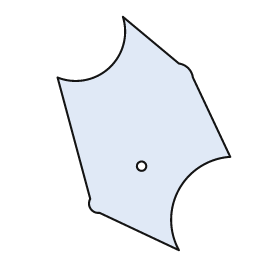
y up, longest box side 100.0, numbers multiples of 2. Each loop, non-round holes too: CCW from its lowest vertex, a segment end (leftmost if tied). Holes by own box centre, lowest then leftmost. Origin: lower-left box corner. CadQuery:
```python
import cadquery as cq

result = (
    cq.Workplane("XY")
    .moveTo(52.0, 0.0)
    .threePointArc((52.0, 26.0), (74.0, 40.0))
    .lineTo(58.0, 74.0)
    .threePointArc((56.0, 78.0), (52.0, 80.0))
    .lineTo(28.0, 100.0)
    .threePointArc((22.0, 78.0), (0.0, 74.0))
    .lineTo(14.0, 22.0)
    .threePointArc((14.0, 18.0), (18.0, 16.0))
    .close()
    .moveTo(36.0, 36.0)
    .circle(2.0)
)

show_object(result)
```